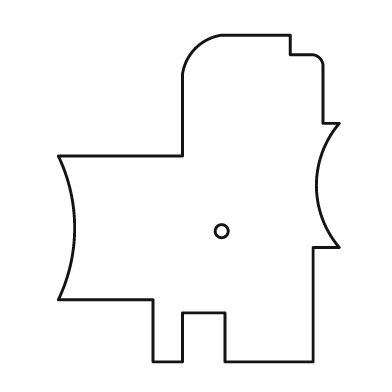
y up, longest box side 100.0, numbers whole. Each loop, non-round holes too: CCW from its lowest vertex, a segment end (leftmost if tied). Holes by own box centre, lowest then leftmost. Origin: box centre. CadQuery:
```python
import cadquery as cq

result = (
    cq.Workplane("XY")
    .moveTo(-14.0, -50.0)
    .lineTo(-5.0, -50.0)
    .lineTo(-5.0, -35.0)
    .lineTo(8.0, -35.0)
    .lineTo(8.0, -50.0)
    .lineTo(35.0, -50.0)
    .lineTo(35.0, -15.0)
    .lineTo(43.0, -15.0)
    .threePointArc((36.0, 4.0), (43.0, 23.0))
    .lineTo(38.0, 23.0)
    .lineTo(38.0, 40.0)
    .threePointArc((37.0, 43.0), (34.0, 44.0))
    .lineTo(28.0, 44.0)
    .lineTo(28.0, 50.0)
    .lineTo(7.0, 50.0)
    .threePointArc((-1.0, 46.0), (-5.0, 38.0))
    .lineTo(-5.0, 13.0)
    .lineTo(-43.0, 13.0)
    .threePointArc((-38.0, -9.0), (-43.0, -31.0))
    .lineTo(-14.0, -31.0)
    .close()
    .moveTo(7.0, -10.0)
    .circle(2.0)
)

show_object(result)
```